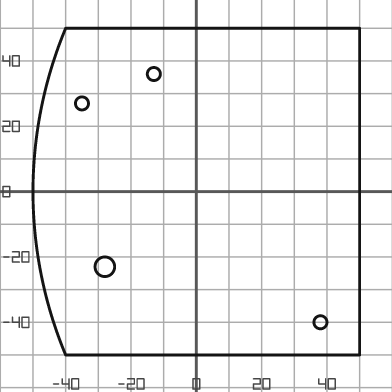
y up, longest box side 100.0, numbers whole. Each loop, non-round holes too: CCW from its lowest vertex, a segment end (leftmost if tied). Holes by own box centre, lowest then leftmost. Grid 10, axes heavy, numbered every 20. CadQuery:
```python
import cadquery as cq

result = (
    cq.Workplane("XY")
    .moveTo(-40.0, -50.0)
    .lineTo(50.0, -50.0)
    .lineTo(50.0, 50.0)
    .lineTo(-40.0, 50.0)
    .threePointArc((-50.0, 0.0), (-40.0, -50.0))
    .close()
    .moveTo(38.0, -40.0)
    .circle(2.0)
    .moveTo(-28.0, -23.0)
    .circle(3.0)
    .moveTo(-35.0, 27.0)
    .circle(2.0)
    .moveTo(-13.0, 36.0)
    .circle(2.0)
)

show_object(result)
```